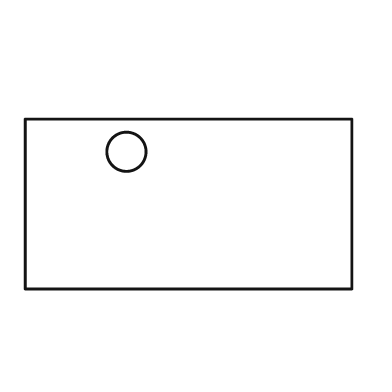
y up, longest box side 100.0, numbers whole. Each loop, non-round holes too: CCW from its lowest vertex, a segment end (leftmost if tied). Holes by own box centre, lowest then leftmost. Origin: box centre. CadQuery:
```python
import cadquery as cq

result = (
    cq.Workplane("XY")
    .moveTo(-50.0, -26.0)
    .lineTo(50.0, -26.0)
    .lineTo(50.0, 26.0)
    .lineTo(-50.0, 26.0)
    .close()
    .moveTo(-19.0, 16.0)
    .circle(6.0)
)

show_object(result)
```